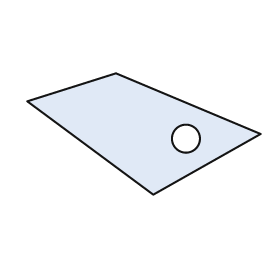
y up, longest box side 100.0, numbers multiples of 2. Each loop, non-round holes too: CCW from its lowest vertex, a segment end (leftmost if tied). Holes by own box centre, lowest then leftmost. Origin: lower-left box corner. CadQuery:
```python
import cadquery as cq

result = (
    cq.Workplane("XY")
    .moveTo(54.0, 0.0)
    .lineTo(100.0, 26.0)
    .lineTo(38.0, 52.0)
    .lineTo(0.0, 40.0)
    .close()
    .moveTo(68.0, 24.0)
    .circle(6.0)
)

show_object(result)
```